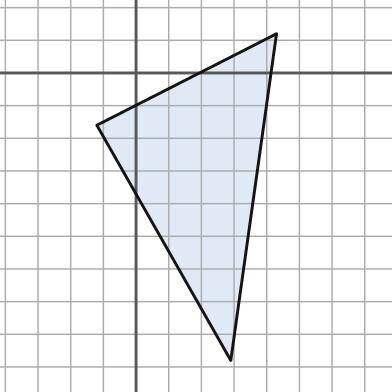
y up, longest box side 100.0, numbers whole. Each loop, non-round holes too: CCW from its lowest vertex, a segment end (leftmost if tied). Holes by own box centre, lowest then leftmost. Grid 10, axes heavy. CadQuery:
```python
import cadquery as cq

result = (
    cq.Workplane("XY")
    .moveTo(29.0, -88.0)
    .lineTo(43.0, 12.0)
    .lineTo(-12.0, -16.0)
    .close()
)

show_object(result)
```